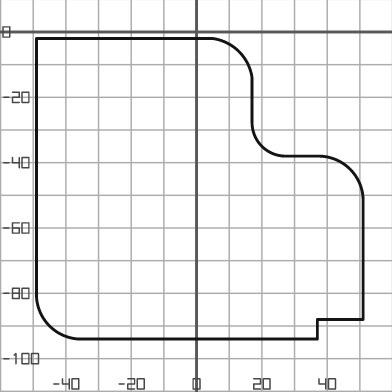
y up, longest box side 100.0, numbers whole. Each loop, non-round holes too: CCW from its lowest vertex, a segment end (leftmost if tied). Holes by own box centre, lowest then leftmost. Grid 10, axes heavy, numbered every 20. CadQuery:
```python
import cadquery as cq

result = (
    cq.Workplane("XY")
    .moveTo(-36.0, -94.0)
    .lineTo(37.0, -94.0)
    .lineTo(37.0, -88.0)
    .lineTo(51.0, -88.0)
    .lineTo(51.0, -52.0)
    .threePointArc((47.0, -42.0), (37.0, -38.0))
    .lineTo(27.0, -38.0)
    .threePointArc((20.0, -35.0), (17.0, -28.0))
    .lineTo(17.0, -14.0)
    .threePointArc((13.0, -6.0), (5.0, -2.0))
    .lineTo(-49.0, -2.0)
    .lineTo(-49.0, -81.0)
    .threePointArc((-45.0, -90.0), (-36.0, -94.0))
    .close()
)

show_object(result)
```